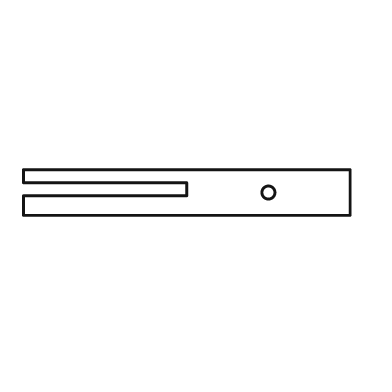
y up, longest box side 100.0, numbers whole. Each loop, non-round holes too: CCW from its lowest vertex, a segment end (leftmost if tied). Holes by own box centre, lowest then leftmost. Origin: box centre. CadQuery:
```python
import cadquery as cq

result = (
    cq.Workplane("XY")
    .moveTo(-50.0, -7.0)
    .lineTo(50.0, -7.0)
    .lineTo(50.0, 7.0)
    .lineTo(-50.0, 7.0)
    .lineTo(-50.0, 3.0)
    .lineTo(0.0, 3.0)
    .lineTo(0.0, -1.0)
    .lineTo(-50.0, -1.0)
    .close()
    .moveTo(25.0, 0.0)
    .circle(2.0)
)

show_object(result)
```